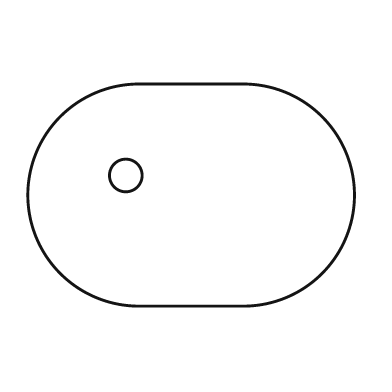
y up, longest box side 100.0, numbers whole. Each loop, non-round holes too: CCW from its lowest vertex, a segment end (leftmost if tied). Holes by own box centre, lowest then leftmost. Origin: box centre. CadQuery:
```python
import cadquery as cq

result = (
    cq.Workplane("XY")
    .moveTo(-16.0, -34.0)
    .lineTo(16.0, -34.0)
    .threePointArc((50.0, 0.0), (16.0, 34.0))
    .lineTo(-16.0, 34.0)
    .threePointArc((-50.0, 0.0), (-16.0, -34.0))
    .close()
    .moveTo(-20.0, 6.0)
    .circle(5.0)
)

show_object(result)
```